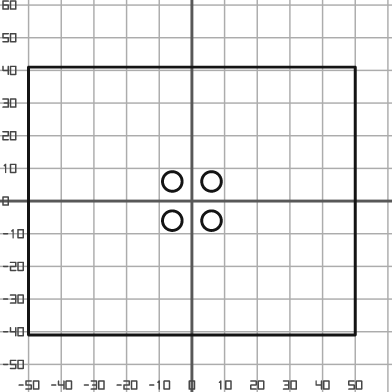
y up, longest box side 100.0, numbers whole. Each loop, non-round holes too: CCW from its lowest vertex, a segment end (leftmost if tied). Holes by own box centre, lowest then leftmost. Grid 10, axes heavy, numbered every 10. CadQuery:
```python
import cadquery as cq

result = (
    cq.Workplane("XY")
    .moveTo(-50.0, -41.0)
    .lineTo(50.0, -41.0)
    .lineTo(50.0, 41.0)
    .lineTo(-50.0, 41.0)
    .close()
    .moveTo(-6.0, -6.0)
    .circle(3.0)
    .moveTo(6.0, -6.0)
    .circle(3.0)
    .moveTo(-6.0, 6.0)
    .circle(3.0)
    .moveTo(6.0, 6.0)
    .circle(3.0)
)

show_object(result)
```